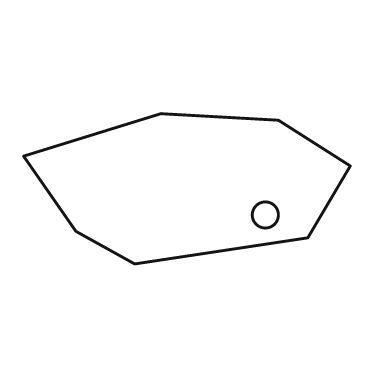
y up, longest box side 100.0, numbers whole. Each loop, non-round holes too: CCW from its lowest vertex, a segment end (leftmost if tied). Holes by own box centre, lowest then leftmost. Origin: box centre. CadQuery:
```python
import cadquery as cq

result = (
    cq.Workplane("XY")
    .moveTo(-16.0, -23.0)
    .lineTo(37.0, -15.0)
    .lineTo(50.0, 7.0)
    .lineTo(28.0, 21.0)
    .lineTo(-8.0, 23.0)
    .lineTo(-50.0, 10.0)
    .lineTo(-34.0, -13.0)
    .close()
    .moveTo(24.0, -8.0)
    .circle(4.0)
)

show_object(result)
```